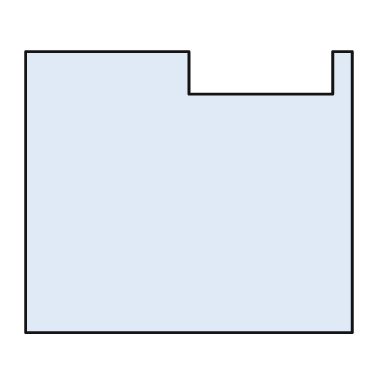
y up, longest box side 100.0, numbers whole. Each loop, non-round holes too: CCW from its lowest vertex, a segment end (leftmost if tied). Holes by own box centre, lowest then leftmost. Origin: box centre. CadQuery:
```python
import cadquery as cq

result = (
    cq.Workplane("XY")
    .moveTo(-50.0, -43.0)
    .lineTo(50.0, -43.0)
    .lineTo(50.0, 43.0)
    .lineTo(44.0, 43.0)
    .lineTo(44.0, 30.0)
    .lineTo(0.0, 30.0)
    .lineTo(0.0, 43.0)
    .lineTo(-50.0, 43.0)
    .close()
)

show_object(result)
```